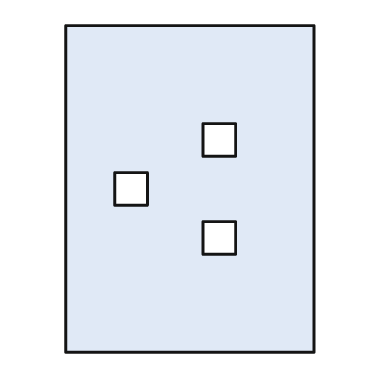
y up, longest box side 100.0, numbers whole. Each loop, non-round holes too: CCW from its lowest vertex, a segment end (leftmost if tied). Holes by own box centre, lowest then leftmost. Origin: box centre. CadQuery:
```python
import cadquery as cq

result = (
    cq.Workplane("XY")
    .moveTo(-38.0, -50.0)
    .lineTo(38.0, -50.0)
    .lineTo(38.0, 50.0)
    .lineTo(-38.0, 50.0)
    .close()
    .moveTo(4.0, -20.0)
    .lineTo(14.0, -20.0)
    .lineTo(14.0, -10.0)
    .lineTo(4.0, -10.0)
    .close()
    .moveTo(-23.0, -5.0)
    .lineTo(-13.0, -5.0)
    .lineTo(-13.0, 5.0)
    .lineTo(-23.0, 5.0)
    .close()
    .moveTo(4.0, 10.0)
    .lineTo(14.0, 10.0)
    .lineTo(14.0, 20.0)
    .lineTo(4.0, 20.0)
    .close()
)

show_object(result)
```